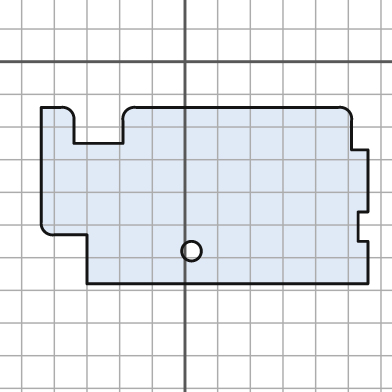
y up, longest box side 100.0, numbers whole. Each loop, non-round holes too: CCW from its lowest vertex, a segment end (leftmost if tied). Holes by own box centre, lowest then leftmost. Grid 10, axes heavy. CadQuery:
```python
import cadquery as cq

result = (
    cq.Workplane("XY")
    .moveTo(-30.0, -68.0)
    .lineTo(56.0, -68.0)
    .lineTo(56.0, -55.0)
    .lineTo(53.0, -55.0)
    .lineTo(53.0, -46.0)
    .lineTo(56.0, -46.0)
    .lineTo(56.0, -27.0)
    .lineTo(51.0, -27.0)
    .lineTo(51.0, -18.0)
    .threePointArc((50.0, -15.0), (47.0, -14.0))
    .lineTo(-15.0, -14.0)
    .threePointArc((-18.0, -15.0), (-19.0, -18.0))
    .lineTo(-19.0, -25.0)
    .lineTo(-34.0, -25.0)
    .lineTo(-34.0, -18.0)
    .threePointArc((-35.0, -15.0), (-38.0, -14.0))
    .lineTo(-44.0, -14.0)
    .lineTo(-44.0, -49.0)
    .threePointArc((-43.0, -52.0), (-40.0, -53.0))
    .lineTo(-30.0, -53.0)
    .close()
    .moveTo(2.0, -58.0)
    .circle(3.0)
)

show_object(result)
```